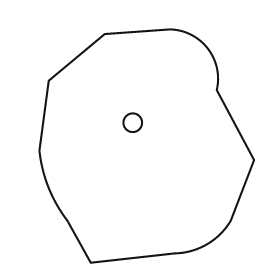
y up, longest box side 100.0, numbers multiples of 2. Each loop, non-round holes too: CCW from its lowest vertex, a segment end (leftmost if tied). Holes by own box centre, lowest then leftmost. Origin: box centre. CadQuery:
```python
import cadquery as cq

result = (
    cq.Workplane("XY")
    .moveTo(-24.0, -50.0)
    .lineTo(12.0, -46.0)
    .threePointArc((26.0, -42.0), (36.0, -32.0))
    .lineTo(46.0, -6.0)
    .lineTo(30.0, 24.0)
    .threePointArc((26.0, 42.0), (10.0, 50.0))
    .lineTo(-18.0, 48.0)
    .lineTo(-42.0, 28.0)
    .lineTo(-46.0, -2.0)
    .threePointArc((-42.0, -18.0), (-34.0, -32.0))
    .close()
    .moveTo(-6.0, 10.0)
    .circle(4.0)
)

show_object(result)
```